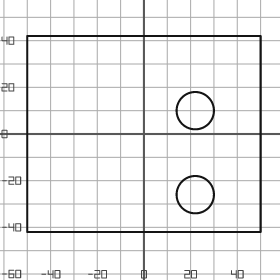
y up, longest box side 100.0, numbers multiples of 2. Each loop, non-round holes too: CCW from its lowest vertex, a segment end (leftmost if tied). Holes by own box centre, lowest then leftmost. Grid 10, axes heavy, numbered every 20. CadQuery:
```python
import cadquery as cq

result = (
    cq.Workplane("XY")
    .moveTo(-50.0, -42.0)
    .lineTo(50.0, -42.0)
    .lineTo(50.0, 42.0)
    .lineTo(-50.0, 42.0)
    .close()
    .moveTo(22.0, -26.0)
    .circle(8.0)
    .moveTo(22.0, 10.0)
    .circle(8.0)
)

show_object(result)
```